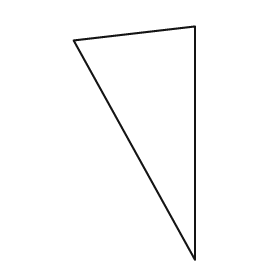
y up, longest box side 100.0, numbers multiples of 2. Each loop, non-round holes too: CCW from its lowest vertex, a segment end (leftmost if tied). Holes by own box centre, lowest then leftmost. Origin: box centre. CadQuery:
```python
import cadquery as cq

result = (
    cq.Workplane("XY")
    .moveTo(26.0, -50.0)
    .lineTo(26.0, 50.0)
    .lineTo(-26.0, 44.0)
    .close()
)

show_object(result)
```